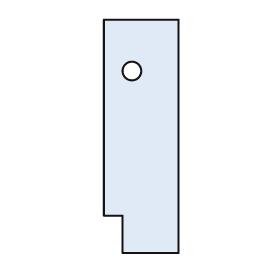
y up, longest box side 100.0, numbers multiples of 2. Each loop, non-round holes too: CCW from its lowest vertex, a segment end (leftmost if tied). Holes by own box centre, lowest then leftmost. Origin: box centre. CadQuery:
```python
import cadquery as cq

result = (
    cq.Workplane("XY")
    .moveTo(-8.0, -50.0)
    .lineTo(16.0, -50.0)
    .lineTo(16.0, 50.0)
    .lineTo(-16.0, 50.0)
    .lineTo(-16.0, -34.0)
    .lineTo(-8.0, -34.0)
    .close()
    .moveTo(-4.0, 28.0)
    .circle(4.0)
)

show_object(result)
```